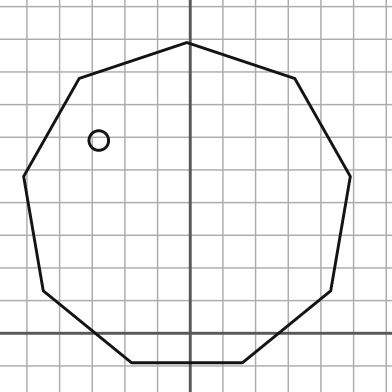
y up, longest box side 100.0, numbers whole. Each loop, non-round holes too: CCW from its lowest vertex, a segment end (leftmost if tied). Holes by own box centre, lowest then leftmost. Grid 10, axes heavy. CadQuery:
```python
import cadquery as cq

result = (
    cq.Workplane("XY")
    .moveTo(-18.0, -9.0)
    .lineTo(16.0, -9.0)
    .lineTo(43.0, 13.0)
    .lineTo(49.0, 48.0)
    .lineTo(32.0, 78.0)
    .lineTo(-1.0, 89.0)
    .lineTo(-34.0, 78.0)
    .lineTo(-51.0, 48.0)
    .lineTo(-45.0, 13.0)
    .close()
    .moveTo(-28.0, 59.0)
    .circle(3.0)
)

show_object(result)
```